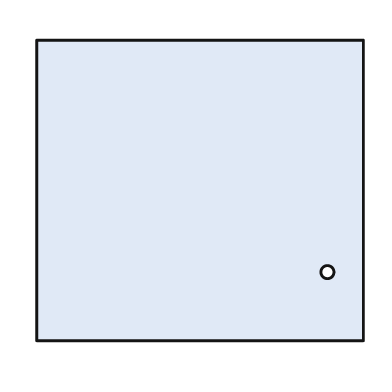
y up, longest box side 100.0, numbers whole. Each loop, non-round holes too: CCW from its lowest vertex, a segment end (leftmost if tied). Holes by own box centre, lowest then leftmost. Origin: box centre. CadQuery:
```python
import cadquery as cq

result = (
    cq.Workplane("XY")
    .moveTo(-50.0, -46.0)
    .lineTo(50.0, -46.0)
    .lineTo(50.0, 46.0)
    .lineTo(-50.0, 46.0)
    .close()
    .moveTo(39.0, -25.0)
    .circle(2.0)
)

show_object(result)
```